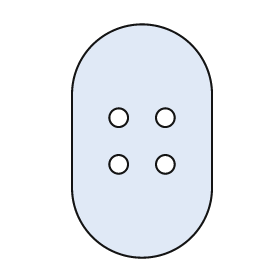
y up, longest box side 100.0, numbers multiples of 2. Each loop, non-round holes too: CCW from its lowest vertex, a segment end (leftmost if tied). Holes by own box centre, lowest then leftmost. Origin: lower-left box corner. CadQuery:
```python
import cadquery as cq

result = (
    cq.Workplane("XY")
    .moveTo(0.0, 30.0)
    .threePointArc((30.0, 0.0), (60.0, 30.0))
    .lineTo(60.0, 70.0)
    .threePointArc((30.0, 100.0), (0.0, 70.0))
    .close()
    .moveTo(20.0, 40.0)
    .circle(4.0)
    .moveTo(40.0, 40.0)
    .circle(4.0)
    .moveTo(20.0, 60.0)
    .circle(4.0)
    .moveTo(40.0, 60.0)
    .circle(4.0)
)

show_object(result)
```